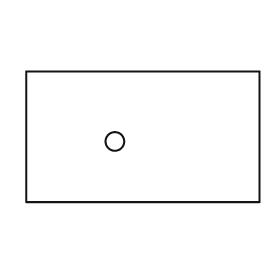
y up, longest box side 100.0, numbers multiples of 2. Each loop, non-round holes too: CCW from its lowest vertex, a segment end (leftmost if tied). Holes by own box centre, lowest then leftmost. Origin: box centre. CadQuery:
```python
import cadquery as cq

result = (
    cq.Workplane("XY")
    .moveTo(-50.0, -28.0)
    .lineTo(50.0, -28.0)
    .lineTo(50.0, 28.0)
    .lineTo(-50.0, 28.0)
    .close()
    .moveTo(-12.0, -2.0)
    .circle(4.0)
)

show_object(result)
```